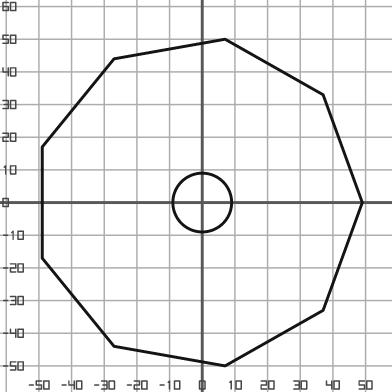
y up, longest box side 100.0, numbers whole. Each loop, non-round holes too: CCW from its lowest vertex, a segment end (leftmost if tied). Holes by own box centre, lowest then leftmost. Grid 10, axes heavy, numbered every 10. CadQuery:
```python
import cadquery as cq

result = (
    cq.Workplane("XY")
    .moveTo(7.0, -50.0)
    .lineTo(37.0, -33.0)
    .lineTo(49.0, 0.0)
    .lineTo(37.0, 33.0)
    .lineTo(7.0, 50.0)
    .lineTo(-27.0, 44.0)
    .lineTo(-49.0, 17.0)
    .lineTo(-49.0, -17.0)
    .lineTo(-27.0, -44.0)
    .close()
    .moveTo(0.0, 0.0)
    .circle(9.0)
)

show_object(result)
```